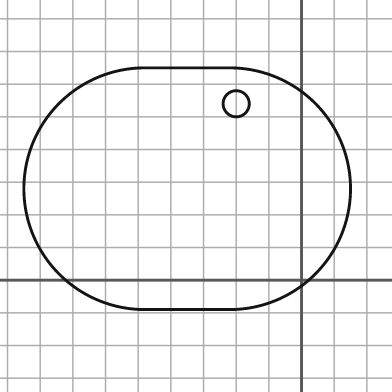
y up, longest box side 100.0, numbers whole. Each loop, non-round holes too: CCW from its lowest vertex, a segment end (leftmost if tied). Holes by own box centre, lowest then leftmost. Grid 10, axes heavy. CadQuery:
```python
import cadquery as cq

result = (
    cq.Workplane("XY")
    .moveTo(-48.0, -9.0)
    .lineTo(-22.0, -9.0)
    .threePointArc((15.0, 28.0), (-22.0, 65.0))
    .lineTo(-48.0, 65.0)
    .threePointArc((-85.0, 28.0), (-48.0, -9.0))
    .close()
    .moveTo(-20.0, 54.0)
    .circle(4.0)
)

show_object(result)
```